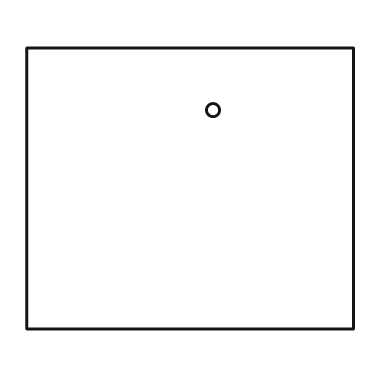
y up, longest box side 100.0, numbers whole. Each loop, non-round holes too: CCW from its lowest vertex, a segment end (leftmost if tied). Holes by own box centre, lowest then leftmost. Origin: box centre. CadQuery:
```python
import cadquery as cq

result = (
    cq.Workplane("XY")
    .moveTo(-50.0, -43.0)
    .lineTo(50.0, -43.0)
    .lineTo(50.0, 43.0)
    .lineTo(-50.0, 43.0)
    .close()
    .moveTo(7.0, 24.0)
    .circle(2.0)
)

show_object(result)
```